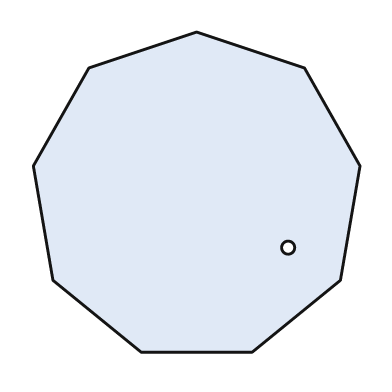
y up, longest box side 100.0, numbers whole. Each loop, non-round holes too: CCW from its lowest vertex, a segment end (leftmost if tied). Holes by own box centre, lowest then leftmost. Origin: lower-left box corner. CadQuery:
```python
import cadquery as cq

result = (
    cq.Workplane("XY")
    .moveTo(33.0, 0.0)
    .lineTo(67.0, 0.0)
    .lineTo(94.0, 22.0)
    .lineTo(100.0, 57.0)
    .lineTo(83.0, 87.0)
    .lineTo(50.0, 98.0)
    .lineTo(17.0, 87.0)
    .lineTo(0.0, 57.0)
    .lineTo(6.0, 22.0)
    .close()
    .moveTo(78.0, 32.0)
    .circle(2.0)
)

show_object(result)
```